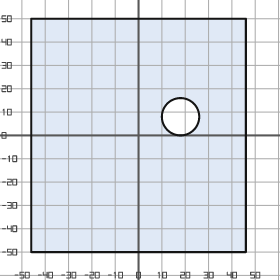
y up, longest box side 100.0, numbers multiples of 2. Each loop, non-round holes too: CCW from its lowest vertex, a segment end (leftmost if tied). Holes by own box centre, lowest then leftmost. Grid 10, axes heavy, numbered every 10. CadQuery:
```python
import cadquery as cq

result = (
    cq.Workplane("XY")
    .moveTo(-46.0, -50.0)
    .lineTo(46.0, -50.0)
    .lineTo(46.0, 50.0)
    .lineTo(-46.0, 50.0)
    .close()
    .moveTo(18.0, 8.0)
    .circle(8.0)
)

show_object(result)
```